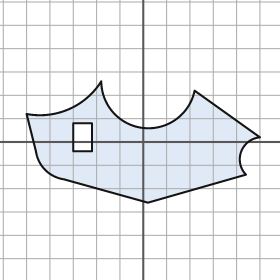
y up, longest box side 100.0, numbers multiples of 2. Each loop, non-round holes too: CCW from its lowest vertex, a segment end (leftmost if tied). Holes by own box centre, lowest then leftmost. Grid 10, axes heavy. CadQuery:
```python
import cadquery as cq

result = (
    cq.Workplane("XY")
    .moveTo(2.0, -26.0)
    .lineTo(44.0, -14.0)
    .threePointArc((42.0, -4.0), (50.0, 2.0))
    .lineTo(22.0, 22.0)
    .threePointArc((0.0, 6.0), (-18.0, 26.0))
    .threePointArc((-32.0, 14.0), (-50.0, 12.0))
    .lineTo(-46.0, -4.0)
    .threePointArc((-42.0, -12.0), (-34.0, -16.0))
    .close()
    .moveTo(-30.0, -4.0)
    .lineTo(-22.0, -4.0)
    .lineTo(-22.0, 8.0)
    .lineTo(-30.0, 8.0)
    .close()
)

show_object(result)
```